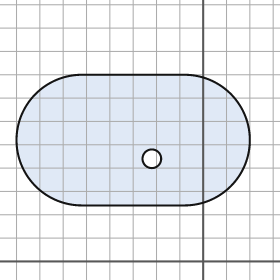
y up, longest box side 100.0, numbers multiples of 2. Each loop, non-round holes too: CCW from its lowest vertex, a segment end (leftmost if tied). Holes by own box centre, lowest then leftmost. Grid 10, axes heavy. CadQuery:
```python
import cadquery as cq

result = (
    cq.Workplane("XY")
    .moveTo(-52.0, 24.0)
    .lineTo(-8.0, 24.0)
    .threePointArc((20.0, 52.0), (-8.0, 80.0))
    .lineTo(-52.0, 80.0)
    .threePointArc((-80.0, 52.0), (-52.0, 24.0))
    .close()
    .moveTo(-22.0, 44.0)
    .circle(4.0)
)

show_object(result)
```